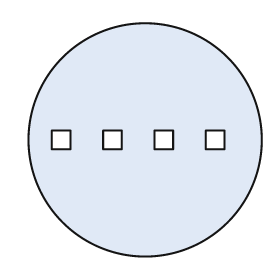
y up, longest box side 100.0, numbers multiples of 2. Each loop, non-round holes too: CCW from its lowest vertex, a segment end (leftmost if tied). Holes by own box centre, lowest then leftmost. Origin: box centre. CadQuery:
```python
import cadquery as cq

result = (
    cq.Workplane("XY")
    .moveTo(0.0, 0.0)
    .circle(50.0)
    .moveTo(-40.0, -4.0)
    .lineTo(-32.0, -4.0)
    .lineTo(-32.0, 4.0)
    .lineTo(-40.0, 4.0)
    .close()
    .moveTo(-18.0, -4.0)
    .lineTo(-10.0, -4.0)
    .lineTo(-10.0, 4.0)
    .lineTo(-18.0, 4.0)
    .close()
    .moveTo(4.0, -4.0)
    .lineTo(12.0, -4.0)
    .lineTo(12.0, 4.0)
    .lineTo(4.0, 4.0)
    .close()
    .moveTo(26.0, -4.0)
    .lineTo(34.0, -4.0)
    .lineTo(34.0, 4.0)
    .lineTo(26.0, 4.0)
    .close()
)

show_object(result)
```